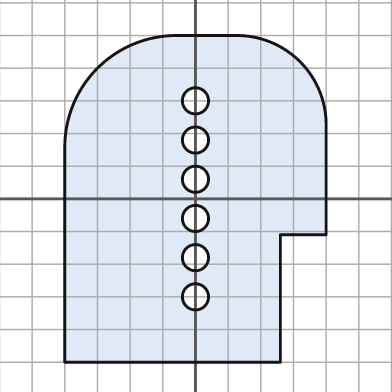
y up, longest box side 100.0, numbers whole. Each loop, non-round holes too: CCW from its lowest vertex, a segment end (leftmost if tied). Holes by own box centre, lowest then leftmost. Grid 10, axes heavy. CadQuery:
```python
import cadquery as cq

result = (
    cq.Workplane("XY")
    .moveTo(-40.0, -50.0)
    .lineTo(26.0, -50.0)
    .lineTo(26.0, -11.0)
    .lineTo(40.0, -11.0)
    .lineTo(40.0, 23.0)
    .threePointArc((32.0, 42.0), (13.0, 50.0))
    .lineTo(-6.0, 50.0)
    .threePointArc((-30.0, 40.0), (-40.0, 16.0))
    .close()
    .moveTo(0.0, -30.0)
    .circle(4.0)
    .moveTo(0.0, -18.0)
    .circle(4.0)
    .moveTo(0.0, -6.0)
    .circle(4.0)
    .moveTo(0.0, 6.0)
    .circle(4.0)
    .moveTo(0.0, 18.0)
    .circle(4.0)
    .moveTo(0.0, 30.0)
    .circle(4.0)
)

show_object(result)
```